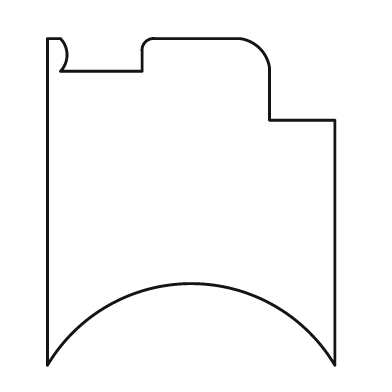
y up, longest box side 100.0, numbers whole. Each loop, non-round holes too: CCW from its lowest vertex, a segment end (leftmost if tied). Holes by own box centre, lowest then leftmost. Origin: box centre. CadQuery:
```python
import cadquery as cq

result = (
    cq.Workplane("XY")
    .moveTo(-44.0, -50.0)
    .threePointArc((0.0, -25.0), (44.0, -50.0))
    .lineTo(44.0, 25.0)
    .lineTo(24.0, 25.0)
    .lineTo(24.0, 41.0)
    .threePointArc((21.0, 47.0), (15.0, 50.0))
    .lineTo(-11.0, 50.0)
    .threePointArc((-14.0, 49.0), (-15.0, 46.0))
    .lineTo(-15.0, 40.0)
    .lineTo(-40.0, 40.0)
    .threePointArc((-38.0, 45.0), (-40.0, 50.0))
    .lineTo(-44.0, 50.0)
    .close()
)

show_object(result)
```